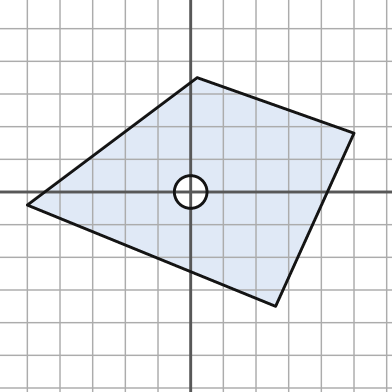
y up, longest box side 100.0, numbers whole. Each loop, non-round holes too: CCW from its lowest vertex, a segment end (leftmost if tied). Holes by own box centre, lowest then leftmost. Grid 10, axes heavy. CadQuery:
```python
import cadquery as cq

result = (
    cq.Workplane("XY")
    .moveTo(26.0, -35.0)
    .lineTo(50.0, 18.0)
    .lineTo(2.0, 35.0)
    .lineTo(-50.0, -4.0)
    .close()
    .moveTo(0.0, 0.0)
    .circle(5.0)
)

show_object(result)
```